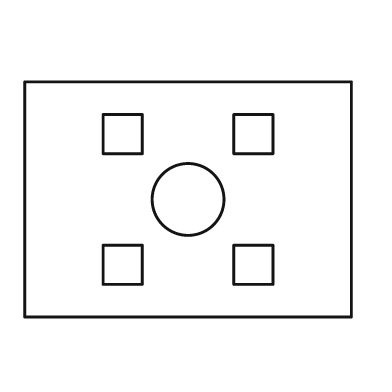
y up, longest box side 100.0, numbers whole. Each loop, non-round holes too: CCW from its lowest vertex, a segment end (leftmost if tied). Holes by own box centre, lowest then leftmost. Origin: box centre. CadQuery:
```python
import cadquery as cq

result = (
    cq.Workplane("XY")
    .moveTo(-50.0, -36.0)
    .lineTo(50.0, -36.0)
    .lineTo(50.0, 36.0)
    .lineTo(-50.0, 36.0)
    .close()
    .moveTo(-26.0, -26.0)
    .lineTo(-14.0, -26.0)
    .lineTo(-14.0, -14.0)
    .lineTo(-26.0, -14.0)
    .close()
    .moveTo(14.0, -26.0)
    .lineTo(26.0, -26.0)
    .lineTo(26.0, -14.0)
    .lineTo(14.0, -14.0)
    .close()
    .moveTo(0.0, 0.0)
    .circle(11.0)
    .moveTo(-26.0, 14.0)
    .lineTo(-14.0, 14.0)
    .lineTo(-14.0, 26.0)
    .lineTo(-26.0, 26.0)
    .close()
    .moveTo(14.0, 14.0)
    .lineTo(26.0, 14.0)
    .lineTo(26.0, 26.0)
    .lineTo(14.0, 26.0)
    .close()
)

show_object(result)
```